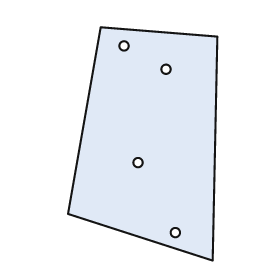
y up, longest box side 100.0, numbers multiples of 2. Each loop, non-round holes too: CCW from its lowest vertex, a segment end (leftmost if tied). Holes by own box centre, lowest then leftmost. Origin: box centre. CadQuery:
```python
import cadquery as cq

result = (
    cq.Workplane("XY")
    .moveTo(30.0, -50.0)
    .lineTo(32.0, 46.0)
    .lineTo(-18.0, 50.0)
    .lineTo(-32.0, -30.0)
    .close()
    .moveTo(14.0, -38.0)
    .circle(2.0)
    .moveTo(-2.0, -8.0)
    .circle(2.0)
    .moveTo(10.0, 32.0)
    .circle(2.0)
    .moveTo(-8.0, 42.0)
    .circle(2.0)
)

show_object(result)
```